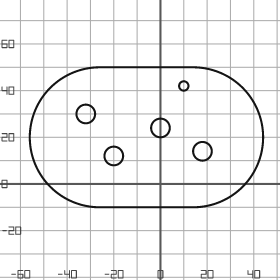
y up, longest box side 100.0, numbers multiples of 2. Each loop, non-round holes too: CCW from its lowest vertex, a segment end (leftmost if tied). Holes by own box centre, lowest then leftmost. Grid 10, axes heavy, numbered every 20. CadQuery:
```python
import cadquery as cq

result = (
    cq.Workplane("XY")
    .moveTo(-26.0, -10.0)
    .lineTo(14.0, -10.0)
    .threePointArc((44.0, 20.0), (14.0, 50.0))
    .lineTo(-26.0, 50.0)
    .threePointArc((-56.0, 20.0), (-26.0, -10.0))
    .close()
    .moveTo(-20.0, 12.0)
    .circle(4.0)
    .moveTo(18.0, 14.0)
    .circle(4.0)
    .moveTo(0.0, 24.0)
    .circle(4.0)
    .moveTo(-32.0, 30.0)
    .circle(4.0)
    .moveTo(10.0, 42.0)
    .circle(2.0)
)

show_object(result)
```